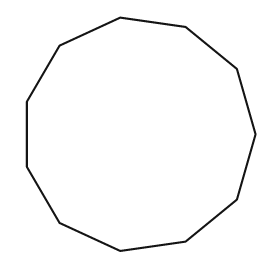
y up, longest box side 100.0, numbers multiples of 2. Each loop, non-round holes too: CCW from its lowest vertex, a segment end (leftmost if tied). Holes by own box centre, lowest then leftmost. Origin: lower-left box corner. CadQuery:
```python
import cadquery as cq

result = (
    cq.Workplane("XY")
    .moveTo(40.0, 0.0)
    .lineTo(68.0, 4.0)
    .lineTo(90.0, 22.0)
    .lineTo(98.0, 50.0)
    .lineTo(90.0, 78.0)
    .lineTo(68.0, 96.0)
    .lineTo(40.0, 100.0)
    .lineTo(14.0, 88.0)
    .lineTo(0.0, 64.0)
    .lineTo(0.0, 36.0)
    .lineTo(14.0, 12.0)
    .close()
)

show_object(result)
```